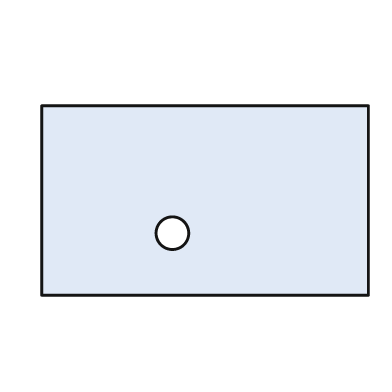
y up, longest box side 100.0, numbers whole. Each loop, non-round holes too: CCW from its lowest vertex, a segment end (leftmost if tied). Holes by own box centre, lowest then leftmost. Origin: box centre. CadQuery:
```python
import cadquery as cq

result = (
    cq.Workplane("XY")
    .moveTo(-50.0, -29.0)
    .lineTo(50.0, -29.0)
    .lineTo(50.0, 29.0)
    .lineTo(-50.0, 29.0)
    .close()
    .moveTo(-10.0, -10.0)
    .circle(5.0)
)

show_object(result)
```